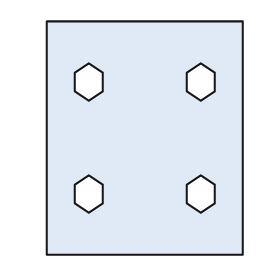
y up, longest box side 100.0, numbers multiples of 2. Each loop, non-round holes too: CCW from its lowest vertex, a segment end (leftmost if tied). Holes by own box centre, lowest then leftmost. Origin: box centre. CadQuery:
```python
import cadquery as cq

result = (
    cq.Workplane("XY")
    .moveTo(-42.0, -50.0)
    .lineTo(42.0, -50.0)
    .lineTo(42.0, 50.0)
    .lineTo(-42.0, 50.0)
    .close()
    .moveTo(-24.0, -32.0)
    .lineTo(-18.0, -28.0)
    .lineTo(-18.0, -20.0)
    .lineTo(-24.0, -16.0)
    .lineTo(-30.0, -20.0)
    .lineTo(-30.0, -28.0)
    .close()
    .moveTo(24.0, -32.0)
    .lineTo(30.0, -28.0)
    .lineTo(30.0, -20.0)
    .lineTo(24.0, -16.0)
    .lineTo(18.0, -20.0)
    .lineTo(18.0, -28.0)
    .close()
    .moveTo(-24.0, 16.0)
    .lineTo(-18.0, 20.0)
    .lineTo(-18.0, 28.0)
    .lineTo(-24.0, 32.0)
    .lineTo(-30.0, 28.0)
    .lineTo(-30.0, 20.0)
    .close()
    .moveTo(24.0, 16.0)
    .lineTo(30.0, 20.0)
    .lineTo(30.0, 28.0)
    .lineTo(24.0, 32.0)
    .lineTo(18.0, 28.0)
    .lineTo(18.0, 20.0)
    .close()
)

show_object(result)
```